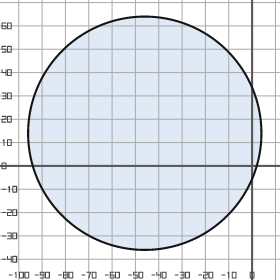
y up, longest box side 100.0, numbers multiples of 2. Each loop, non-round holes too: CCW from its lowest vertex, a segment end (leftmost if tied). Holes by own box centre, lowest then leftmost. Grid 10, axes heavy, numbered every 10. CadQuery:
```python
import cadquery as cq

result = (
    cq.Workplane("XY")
    .moveTo(-46.0, 14.0)
    .circle(50.0)
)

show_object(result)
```